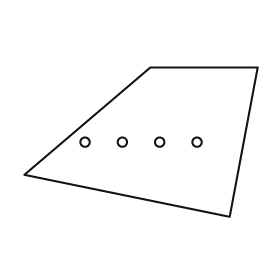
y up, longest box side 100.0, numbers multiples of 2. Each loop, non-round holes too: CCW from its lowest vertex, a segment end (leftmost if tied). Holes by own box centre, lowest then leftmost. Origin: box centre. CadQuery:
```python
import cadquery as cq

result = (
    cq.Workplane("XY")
    .moveTo(38.0, -32.0)
    .lineTo(50.0, 32.0)
    .lineTo(4.0, 32.0)
    .lineTo(-50.0, -14.0)
    .close()
    .moveTo(-24.0, 0.0)
    .circle(2.0)
    .moveTo(-8.0, 0.0)
    .circle(2.0)
    .moveTo(8.0, 0.0)
    .circle(2.0)
    .moveTo(24.0, 0.0)
    .circle(2.0)
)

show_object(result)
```